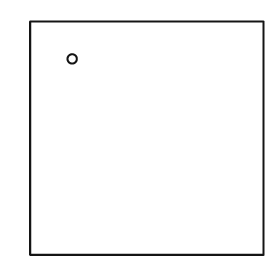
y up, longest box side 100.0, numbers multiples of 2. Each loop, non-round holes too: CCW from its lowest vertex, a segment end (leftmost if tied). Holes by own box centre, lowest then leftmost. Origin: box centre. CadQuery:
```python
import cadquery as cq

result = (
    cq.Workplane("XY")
    .moveTo(-50.0, -50.0)
    .lineTo(50.0, -50.0)
    .lineTo(50.0, 50.0)
    .lineTo(-50.0, 50.0)
    .close()
    .moveTo(-32.0, 34.0)
    .circle(2.0)
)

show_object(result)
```